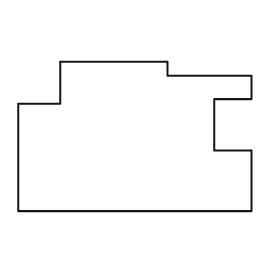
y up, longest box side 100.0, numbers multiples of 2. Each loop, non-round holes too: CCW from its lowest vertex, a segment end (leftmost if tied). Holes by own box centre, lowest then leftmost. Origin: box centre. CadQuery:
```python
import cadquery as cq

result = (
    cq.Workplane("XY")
    .moveTo(-50.0, -32.0)
    .lineTo(50.0, -32.0)
    .lineTo(50.0, -6.0)
    .lineTo(34.0, -6.0)
    .lineTo(34.0, 16.0)
    .lineTo(50.0, 16.0)
    .lineTo(50.0, 26.0)
    .lineTo(14.0, 26.0)
    .lineTo(14.0, 32.0)
    .lineTo(-32.0, 32.0)
    .lineTo(-32.0, 14.0)
    .lineTo(-50.0, 14.0)
    .close()
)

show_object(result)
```